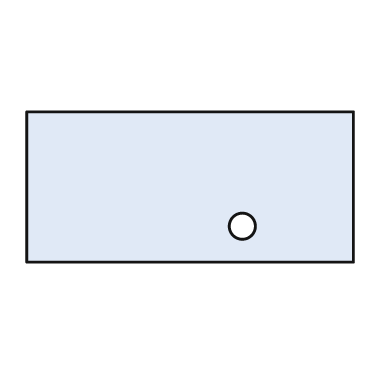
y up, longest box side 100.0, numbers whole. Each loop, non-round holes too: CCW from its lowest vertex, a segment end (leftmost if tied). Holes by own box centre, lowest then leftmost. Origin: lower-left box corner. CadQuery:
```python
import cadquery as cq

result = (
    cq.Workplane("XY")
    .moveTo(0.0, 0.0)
    .lineTo(100.0, 0.0)
    .lineTo(100.0, 46.0)
    .lineTo(0.0, 46.0)
    .close()
    .moveTo(66.0, 11.0)
    .circle(4.0)
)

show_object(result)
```